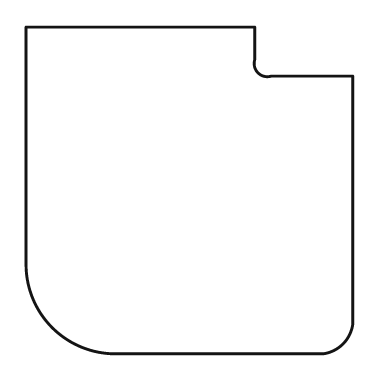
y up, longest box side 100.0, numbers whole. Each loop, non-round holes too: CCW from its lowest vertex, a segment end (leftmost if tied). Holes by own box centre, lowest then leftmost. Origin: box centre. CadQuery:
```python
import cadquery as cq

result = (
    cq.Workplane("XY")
    .moveTo(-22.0, -50.0)
    .lineTo(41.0, -50.0)
    .threePointArc((47.0, -47.0), (50.0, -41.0))
    .lineTo(50.0, 35.0)
    .lineTo(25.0, 35.0)
    .threePointArc((21.0, 36.0), (20.0, 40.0))
    .lineTo(20.0, 50.0)
    .lineTo(-50.0, 50.0)
    .lineTo(-50.0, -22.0)
    .threePointArc((-42.0, -42.0), (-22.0, -50.0))
    .close()
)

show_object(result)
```